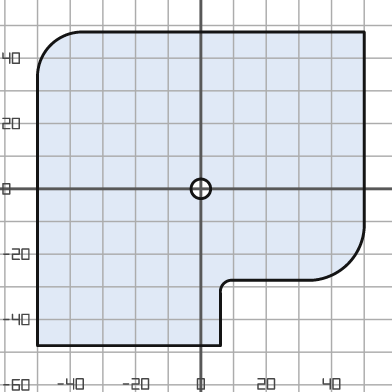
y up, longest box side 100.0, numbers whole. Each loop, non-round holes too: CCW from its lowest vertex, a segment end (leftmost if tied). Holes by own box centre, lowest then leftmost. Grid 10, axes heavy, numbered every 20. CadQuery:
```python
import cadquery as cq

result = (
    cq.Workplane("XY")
    .moveTo(-50.0, -48.0)
    .lineTo(6.0, -48.0)
    .lineTo(6.0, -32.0)
    .threePointArc((7.0, -29.0), (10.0, -28.0))
    .lineTo(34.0, -28.0)
    .threePointArc((45.0, -23.0), (50.0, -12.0))
    .lineTo(50.0, 48.0)
    .lineTo(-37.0, 48.0)
    .threePointArc((-46.0, 44.0), (-50.0, 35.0))
    .close()
    .moveTo(0.0, 0.0)
    .circle(3.0)
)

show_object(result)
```